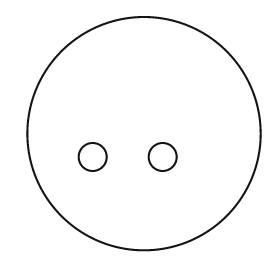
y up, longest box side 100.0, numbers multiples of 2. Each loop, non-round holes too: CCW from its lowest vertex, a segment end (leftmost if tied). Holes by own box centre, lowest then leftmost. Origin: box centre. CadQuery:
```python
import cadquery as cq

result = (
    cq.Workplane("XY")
    .moveTo(0.0, 0.0)
    .circle(50.0)
    .moveTo(-22.0, -10.0)
    .circle(6.0)
    .moveTo(8.0, -10.0)
    .circle(6.0)
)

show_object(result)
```